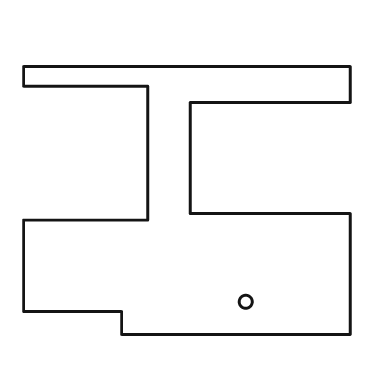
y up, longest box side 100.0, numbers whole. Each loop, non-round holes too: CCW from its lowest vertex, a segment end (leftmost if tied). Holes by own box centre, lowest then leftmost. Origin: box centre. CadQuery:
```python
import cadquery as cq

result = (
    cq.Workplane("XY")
    .moveTo(-20.0, -41.0)
    .lineTo(50.0, -41.0)
    .lineTo(50.0, -4.0)
    .lineTo(1.0, -4.0)
    .lineTo(1.0, 30.0)
    .lineTo(50.0, 30.0)
    .lineTo(50.0, 41.0)
    .lineTo(-50.0, 41.0)
    .lineTo(-50.0, 35.0)
    .lineTo(-12.0, 35.0)
    .lineTo(-12.0, -6.0)
    .lineTo(-50.0, -6.0)
    .lineTo(-50.0, -34.0)
    .lineTo(-20.0, -34.0)
    .close()
    .moveTo(18.0, -31.0)
    .circle(2.0)
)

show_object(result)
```